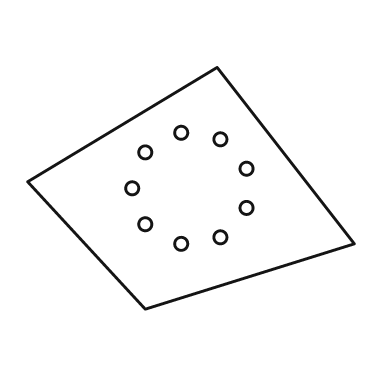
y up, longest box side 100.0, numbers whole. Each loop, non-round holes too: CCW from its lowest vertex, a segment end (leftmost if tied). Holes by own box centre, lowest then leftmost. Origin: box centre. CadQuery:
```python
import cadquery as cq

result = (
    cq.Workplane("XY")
    .moveTo(-14.0, -37.0)
    .lineTo(50.0, -17.0)
    .lineTo(8.0, 37.0)
    .lineTo(-50.0, 2.0)
    .close()
    .moveTo(-3.0, -17.0)
    .circle(2.0)
    .moveTo(9.0, -15.0)
    .circle(2.0)
    .moveTo(-14.0, -11.0)
    .circle(2.0)
    .moveTo(17.0, -6.0)
    .circle(2.0)
    .moveTo(-18.0, 0.0)
    .circle(2.0)
    .moveTo(17.0, 6.0)
    .circle(2.0)
    .moveTo(-14.0, 11.0)
    .circle(2.0)
    .moveTo(9.0, 15.0)
    .circle(2.0)
    .moveTo(-3.0, 17.0)
    .circle(2.0)
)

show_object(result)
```